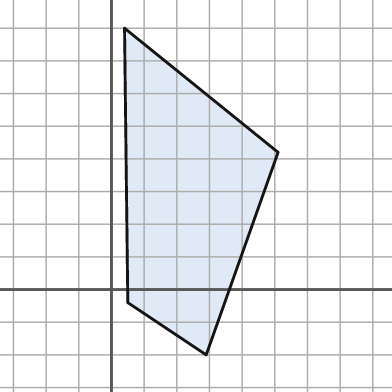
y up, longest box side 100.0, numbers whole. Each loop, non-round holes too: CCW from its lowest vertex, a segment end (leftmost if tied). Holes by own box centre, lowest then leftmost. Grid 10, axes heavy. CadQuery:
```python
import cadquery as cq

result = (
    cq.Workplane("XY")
    .moveTo(29.0, -20.0)
    .lineTo(51.0, 42.0)
    .lineTo(4.0, 80.0)
    .lineTo(5.0, -4.0)
    .close()
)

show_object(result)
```